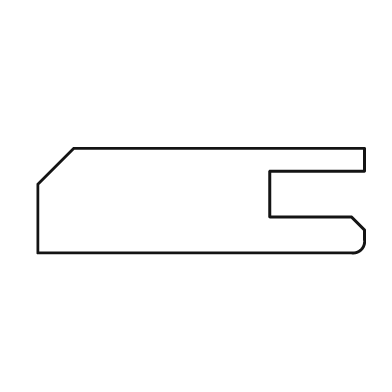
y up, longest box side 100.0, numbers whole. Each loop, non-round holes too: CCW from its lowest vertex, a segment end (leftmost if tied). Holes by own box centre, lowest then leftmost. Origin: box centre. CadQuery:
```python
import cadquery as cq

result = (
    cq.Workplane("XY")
    .moveTo(-50.0, -16.0)
    .lineTo(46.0, -16.0)
    .threePointArc((49.0, -15.0), (50.0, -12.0))
    .lineTo(50.0, -9.0)
    .lineTo(46.0, -5.0)
    .lineTo(21.0, -5.0)
    .lineTo(21.0, 9.0)
    .lineTo(50.0, 9.0)
    .lineTo(50.0, 16.0)
    .lineTo(-39.0, 16.0)
    .lineTo(-50.0, 5.0)
    .close()
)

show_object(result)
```